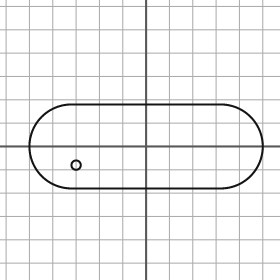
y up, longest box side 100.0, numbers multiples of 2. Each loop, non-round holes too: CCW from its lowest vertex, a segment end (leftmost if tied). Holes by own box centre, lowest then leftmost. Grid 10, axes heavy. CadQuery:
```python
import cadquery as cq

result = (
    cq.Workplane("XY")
    .moveTo(-32.0, -18.0)
    .lineTo(32.0, -18.0)
    .threePointArc((50.0, 0.0), (32.0, 18.0))
    .lineTo(-32.0, 18.0)
    .threePointArc((-50.0, 0.0), (-32.0, -18.0))
    .close()
    .moveTo(-30.0, -8.0)
    .circle(2.0)
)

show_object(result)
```